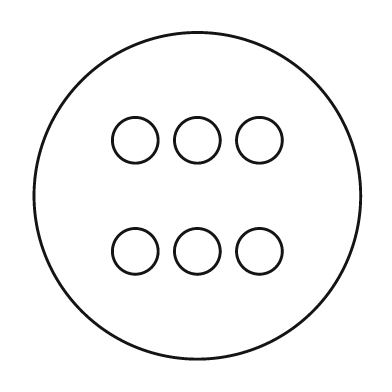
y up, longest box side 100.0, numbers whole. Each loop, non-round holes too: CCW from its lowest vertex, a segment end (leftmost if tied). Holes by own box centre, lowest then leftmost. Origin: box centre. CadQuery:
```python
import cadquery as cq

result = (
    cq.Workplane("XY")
    .moveTo(0.0, 0.0)
    .circle(50.0)
    .moveTo(-19.0, -17.0)
    .circle(7.0)
    .moveTo(0.0, -17.0)
    .circle(7.0)
    .moveTo(19.0, -17.0)
    .circle(7.0)
    .moveTo(-19.0, 17.0)
    .circle(7.0)
    .moveTo(0.0, 17.0)
    .circle(7.0)
    .moveTo(19.0, 17.0)
    .circle(7.0)
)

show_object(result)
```